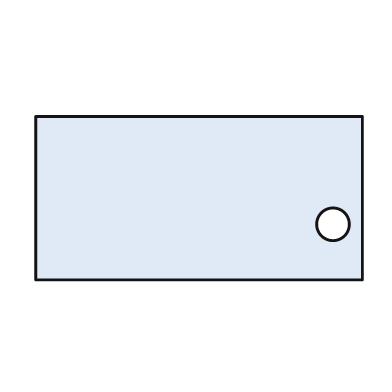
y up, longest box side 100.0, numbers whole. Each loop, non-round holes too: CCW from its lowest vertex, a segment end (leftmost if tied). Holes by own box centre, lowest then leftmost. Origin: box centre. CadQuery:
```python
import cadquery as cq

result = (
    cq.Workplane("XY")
    .moveTo(-50.0, -25.0)
    .lineTo(50.0, -25.0)
    .lineTo(50.0, 25.0)
    .lineTo(-50.0, 25.0)
    .close()
    .moveTo(41.0, -8.0)
    .circle(5.0)
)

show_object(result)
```